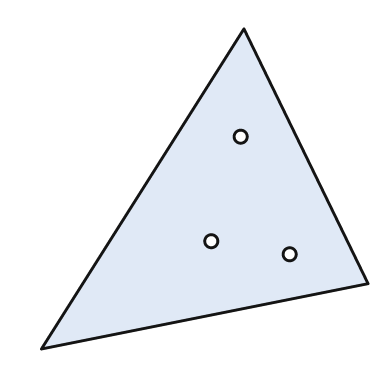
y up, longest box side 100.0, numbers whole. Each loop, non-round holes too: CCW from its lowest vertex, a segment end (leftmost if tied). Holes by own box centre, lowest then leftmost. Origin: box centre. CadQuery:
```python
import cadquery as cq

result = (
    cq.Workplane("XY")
    .moveTo(-50.0, -49.0)
    .lineTo(50.0, -29.0)
    .lineTo(12.0, 49.0)
    .close()
    .moveTo(26.0, -20.0)
    .circle(2.0)
    .moveTo(2.0, -16.0)
    .circle(2.0)
    .moveTo(11.0, 16.0)
    .circle(2.0)
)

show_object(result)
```